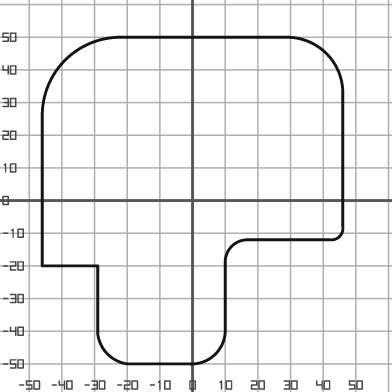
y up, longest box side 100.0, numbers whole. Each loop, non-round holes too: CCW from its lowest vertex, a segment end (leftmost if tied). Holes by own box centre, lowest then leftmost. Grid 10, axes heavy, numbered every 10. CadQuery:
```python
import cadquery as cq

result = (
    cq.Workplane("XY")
    .moveTo(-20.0, -50.0)
    .lineTo(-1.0, -50.0)
    .threePointArc((7.0, -47.0), (10.0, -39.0))
    .lineTo(10.0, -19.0)
    .threePointArc((12.0, -14.0), (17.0, -12.0))
    .lineTo(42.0, -12.0)
    .threePointArc((45.0, -11.0), (46.0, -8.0))
    .lineTo(46.0, 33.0)
    .threePointArc((41.0, 45.0), (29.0, 50.0))
    .lineTo(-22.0, 50.0)
    .threePointArc((-39.0, 43.0), (-46.0, 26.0))
    .lineTo(-46.0, -20.0)
    .lineTo(-29.0, -20.0)
    .lineTo(-29.0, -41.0)
    .threePointArc((-26.0, -47.0), (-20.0, -50.0))
    .close()
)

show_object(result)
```